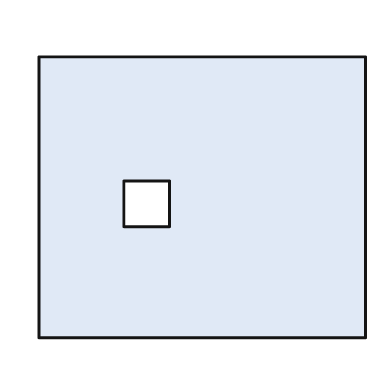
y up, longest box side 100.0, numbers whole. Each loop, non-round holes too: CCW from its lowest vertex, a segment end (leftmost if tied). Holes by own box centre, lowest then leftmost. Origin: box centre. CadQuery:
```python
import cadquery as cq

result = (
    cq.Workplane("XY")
    .moveTo(-50.0, -43.0)
    .lineTo(50.0, -43.0)
    .lineTo(50.0, 43.0)
    .lineTo(-50.0, 43.0)
    .close()
    .moveTo(-24.0, -9.0)
    .lineTo(-10.0, -9.0)
    .lineTo(-10.0, 5.0)
    .lineTo(-24.0, 5.0)
    .close()
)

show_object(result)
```